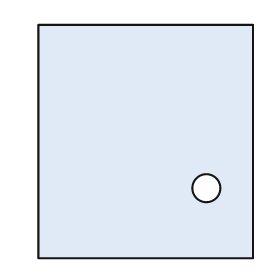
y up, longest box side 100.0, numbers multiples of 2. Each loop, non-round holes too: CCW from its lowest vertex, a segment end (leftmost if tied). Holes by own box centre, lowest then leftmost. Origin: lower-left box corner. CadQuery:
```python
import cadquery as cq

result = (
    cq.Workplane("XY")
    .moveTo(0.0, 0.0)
    .lineTo(92.0, 0.0)
    .lineTo(92.0, 100.0)
    .lineTo(0.0, 100.0)
    .close()
    .moveTo(72.0, 30.0)
    .circle(6.0)
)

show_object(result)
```